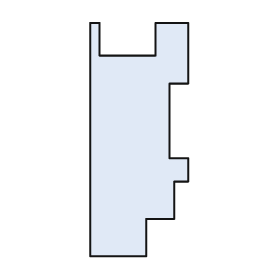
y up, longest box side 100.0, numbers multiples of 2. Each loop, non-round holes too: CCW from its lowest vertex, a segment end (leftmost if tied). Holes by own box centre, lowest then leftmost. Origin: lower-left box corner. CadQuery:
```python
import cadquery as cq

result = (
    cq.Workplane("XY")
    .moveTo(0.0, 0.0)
    .lineTo(24.0, 0.0)
    .lineTo(24.0, 16.0)
    .lineTo(36.0, 16.0)
    .lineTo(36.0, 32.0)
    .lineTo(42.0, 32.0)
    .lineTo(42.0, 42.0)
    .lineTo(34.0, 42.0)
    .lineTo(34.0, 74.0)
    .lineTo(42.0, 74.0)
    .lineTo(42.0, 100.0)
    .lineTo(28.0, 100.0)
    .lineTo(28.0, 86.0)
    .lineTo(4.0, 86.0)
    .lineTo(4.0, 100.0)
    .lineTo(0.0, 100.0)
    .close()
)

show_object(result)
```